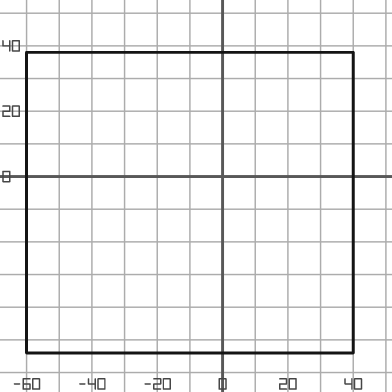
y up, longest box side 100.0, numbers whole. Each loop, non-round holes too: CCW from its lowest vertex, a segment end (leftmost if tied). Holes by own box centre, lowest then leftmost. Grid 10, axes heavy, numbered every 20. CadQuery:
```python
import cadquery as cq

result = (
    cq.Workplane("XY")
    .moveTo(-60.0, -54.0)
    .lineTo(40.0, -54.0)
    .lineTo(40.0, 38.0)
    .lineTo(-60.0, 38.0)
    .close()
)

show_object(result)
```